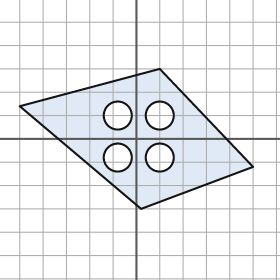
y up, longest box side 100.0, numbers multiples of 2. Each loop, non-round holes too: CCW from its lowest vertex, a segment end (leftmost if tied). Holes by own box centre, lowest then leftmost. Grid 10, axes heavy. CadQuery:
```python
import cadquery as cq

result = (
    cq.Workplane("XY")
    .moveTo(2.0, -30.0)
    .lineTo(50.0, -12.0)
    .lineTo(10.0, 30.0)
    .lineTo(-50.0, 14.0)
    .close()
    .moveTo(-8.0, -8.0)
    .circle(6.0)
    .moveTo(10.0, -8.0)
    .circle(6.0)
    .moveTo(-8.0, 10.0)
    .circle(6.0)
    .moveTo(10.0, 10.0)
    .circle(6.0)
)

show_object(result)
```